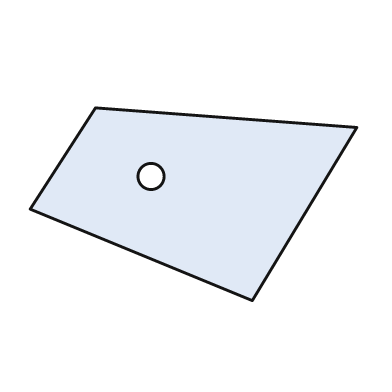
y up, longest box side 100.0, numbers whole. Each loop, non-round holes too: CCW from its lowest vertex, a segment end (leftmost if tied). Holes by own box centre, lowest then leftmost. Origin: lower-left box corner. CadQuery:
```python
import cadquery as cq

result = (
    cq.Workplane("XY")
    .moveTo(68.0, 0.0)
    .lineTo(100.0, 53.0)
    .lineTo(20.0, 59.0)
    .lineTo(0.0, 28.0)
    .close()
    .moveTo(37.0, 38.0)
    .circle(4.0)
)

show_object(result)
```